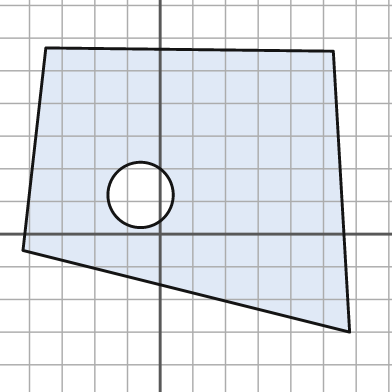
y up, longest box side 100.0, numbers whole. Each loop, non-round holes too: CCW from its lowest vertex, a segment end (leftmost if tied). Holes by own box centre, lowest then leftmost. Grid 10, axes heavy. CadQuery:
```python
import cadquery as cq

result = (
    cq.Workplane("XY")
    .moveTo(58.0, -30.0)
    .lineTo(53.0, 56.0)
    .lineTo(-35.0, 57.0)
    .lineTo(-42.0, -5.0)
    .close()
    .moveTo(-6.0, 12.0)
    .circle(10.0)
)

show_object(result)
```